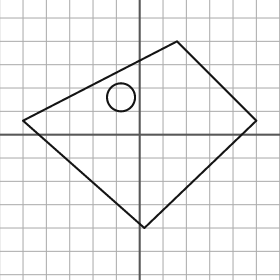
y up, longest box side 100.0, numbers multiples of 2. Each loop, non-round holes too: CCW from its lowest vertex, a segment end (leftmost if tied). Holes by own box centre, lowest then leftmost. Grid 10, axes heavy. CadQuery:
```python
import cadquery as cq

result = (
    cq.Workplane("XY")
    .moveTo(2.0, -40.0)
    .lineTo(50.0, 6.0)
    .lineTo(16.0, 40.0)
    .lineTo(-50.0, 6.0)
    .close()
    .moveTo(-8.0, 16.0)
    .circle(6.0)
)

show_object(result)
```